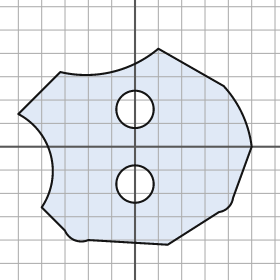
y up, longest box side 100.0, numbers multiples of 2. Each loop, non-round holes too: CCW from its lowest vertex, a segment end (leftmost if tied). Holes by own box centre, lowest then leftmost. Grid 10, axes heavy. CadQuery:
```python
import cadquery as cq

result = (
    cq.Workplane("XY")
    .moveTo(14.0, -42.0)
    .lineTo(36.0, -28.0)
    .threePointArc((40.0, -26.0), (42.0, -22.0))
    .lineTo(50.0, 0.0)
    .threePointArc((46.0, 14.0), (38.0, 26.0))
    .lineTo(10.0, 42.0)
    .threePointArc((-10.0, 32.0), (-32.0, 32.0))
    .lineTo(-50.0, 14.0)
    .threePointArc((-36.0, -4.0), (-40.0, -26.0))
    .lineTo(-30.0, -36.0)
    .threePointArc((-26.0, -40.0), (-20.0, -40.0))
    .close()
    .moveTo(0.0, -16.0)
    .circle(8.0)
    .moveTo(0.0, 16.0)
    .circle(8.0)
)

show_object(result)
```